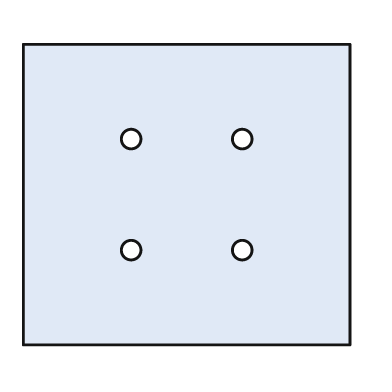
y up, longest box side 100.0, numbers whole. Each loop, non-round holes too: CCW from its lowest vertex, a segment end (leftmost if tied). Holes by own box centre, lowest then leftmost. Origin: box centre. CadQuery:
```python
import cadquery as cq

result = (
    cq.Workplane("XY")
    .moveTo(-50.0, -46.0)
    .lineTo(50.0, -46.0)
    .lineTo(50.0, 46.0)
    .lineTo(-50.0, 46.0)
    .close()
    .moveTo(-17.0, -17.0)
    .circle(3.0)
    .moveTo(17.0, -17.0)
    .circle(3.0)
    .moveTo(-17.0, 17.0)
    .circle(3.0)
    .moveTo(17.0, 17.0)
    .circle(3.0)
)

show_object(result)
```